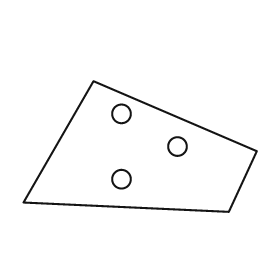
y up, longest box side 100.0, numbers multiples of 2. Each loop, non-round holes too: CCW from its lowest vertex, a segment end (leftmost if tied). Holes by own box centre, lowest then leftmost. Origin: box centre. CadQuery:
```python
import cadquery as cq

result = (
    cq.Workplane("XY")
    .moveTo(38.0, -28.0)
    .lineTo(50.0, -2.0)
    .lineTo(-20.0, 28.0)
    .lineTo(-50.0, -24.0)
    .close()
    .moveTo(-8.0, -14.0)
    .circle(4.0)
    .moveTo(16.0, 0.0)
    .circle(4.0)
    .moveTo(-8.0, 14.0)
    .circle(4.0)
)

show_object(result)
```